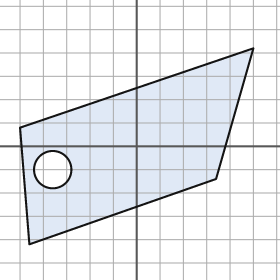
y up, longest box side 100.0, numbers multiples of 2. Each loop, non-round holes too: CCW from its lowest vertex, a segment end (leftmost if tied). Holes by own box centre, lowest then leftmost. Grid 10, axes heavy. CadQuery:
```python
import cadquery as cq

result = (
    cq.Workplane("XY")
    .moveTo(-46.0, -42.0)
    .lineTo(34.0, -14.0)
    .lineTo(50.0, 42.0)
    .lineTo(-50.0, 8.0)
    .close()
    .moveTo(-36.0, -10.0)
    .circle(8.0)
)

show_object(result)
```